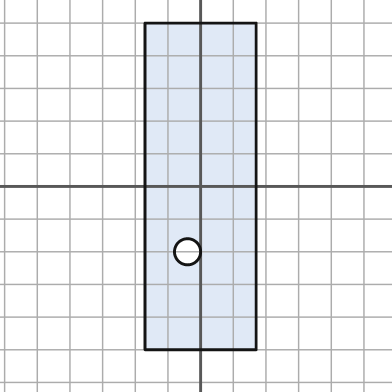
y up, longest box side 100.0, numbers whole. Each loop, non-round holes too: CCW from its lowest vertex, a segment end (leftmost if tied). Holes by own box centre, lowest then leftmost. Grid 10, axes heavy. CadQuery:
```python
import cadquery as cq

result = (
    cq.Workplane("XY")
    .moveTo(-17.0, -50.0)
    .lineTo(17.0, -50.0)
    .lineTo(17.0, 50.0)
    .lineTo(-17.0, 50.0)
    .close()
    .moveTo(-4.0, -20.0)
    .circle(4.0)
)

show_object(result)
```